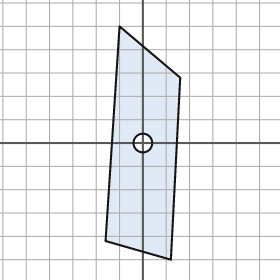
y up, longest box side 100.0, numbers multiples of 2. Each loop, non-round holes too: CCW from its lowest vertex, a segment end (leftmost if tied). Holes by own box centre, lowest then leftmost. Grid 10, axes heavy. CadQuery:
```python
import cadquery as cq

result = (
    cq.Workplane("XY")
    .moveTo(12.0, -50.0)
    .lineTo(16.0, 28.0)
    .lineTo(-10.0, 50.0)
    .lineTo(-16.0, -42.0)
    .close()
    .moveTo(0.0, 0.0)
    .circle(4.0)
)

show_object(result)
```